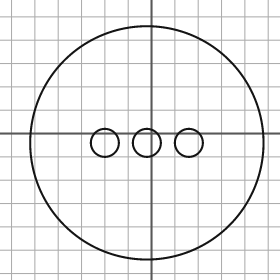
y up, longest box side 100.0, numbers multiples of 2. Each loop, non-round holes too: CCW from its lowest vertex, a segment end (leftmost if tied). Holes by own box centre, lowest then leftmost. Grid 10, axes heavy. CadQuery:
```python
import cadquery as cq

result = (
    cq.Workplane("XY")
    .moveTo(-2.0, -4.0)
    .circle(50.0)
    .moveTo(-20.0, -4.0)
    .circle(6.0)
    .moveTo(-2.0, -4.0)
    .circle(6.0)
    .moveTo(16.0, -4.0)
    .circle(6.0)
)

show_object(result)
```